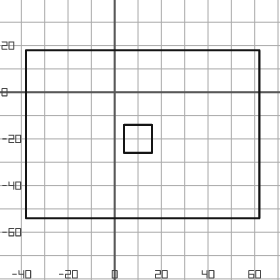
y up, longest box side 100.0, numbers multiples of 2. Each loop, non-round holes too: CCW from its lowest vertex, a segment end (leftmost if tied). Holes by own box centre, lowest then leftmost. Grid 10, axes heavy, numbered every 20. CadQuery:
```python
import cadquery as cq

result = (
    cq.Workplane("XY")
    .moveTo(-38.0, -54.0)
    .lineTo(62.0, -54.0)
    .lineTo(62.0, 18.0)
    .lineTo(-38.0, 18.0)
    .close()
    .moveTo(4.0, -26.0)
    .lineTo(16.0, -26.0)
    .lineTo(16.0, -14.0)
    .lineTo(4.0, -14.0)
    .close()
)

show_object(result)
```